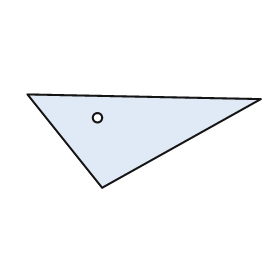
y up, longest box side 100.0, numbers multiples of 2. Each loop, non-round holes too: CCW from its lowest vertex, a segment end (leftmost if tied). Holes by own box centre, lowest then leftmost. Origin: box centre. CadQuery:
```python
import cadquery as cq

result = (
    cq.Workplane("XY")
    .moveTo(-18.0, -20.0)
    .lineTo(50.0, 18.0)
    .lineTo(-50.0, 20.0)
    .close()
    .moveTo(-20.0, 10.0)
    .circle(2.0)
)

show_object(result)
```